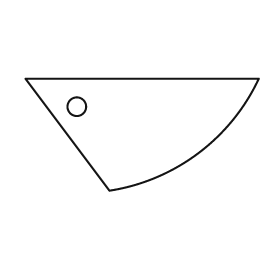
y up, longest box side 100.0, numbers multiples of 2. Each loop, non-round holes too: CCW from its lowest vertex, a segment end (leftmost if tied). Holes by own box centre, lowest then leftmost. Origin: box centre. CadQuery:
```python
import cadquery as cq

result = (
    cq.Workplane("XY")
    .moveTo(-14.0, -24.0)
    .threePointArc((24.0, -8.0), (50.0, 24.0))
    .lineTo(-50.0, 24.0)
    .close()
    .moveTo(-28.0, 12.0)
    .circle(4.0)
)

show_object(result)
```